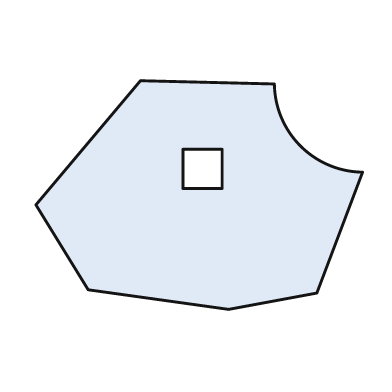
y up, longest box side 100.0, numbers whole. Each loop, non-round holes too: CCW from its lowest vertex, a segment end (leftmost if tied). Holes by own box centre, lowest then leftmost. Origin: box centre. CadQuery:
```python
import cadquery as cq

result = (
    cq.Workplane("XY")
    .moveTo(9.0, -35.0)
    .lineTo(36.0, -30.0)
    .lineTo(50.0, 7.0)
    .threePointArc((31.0, 15.0), (23.0, 34.0))
    .lineTo(-18.0, 35.0)
    .lineTo(-50.0, -3.0)
    .lineTo(-34.0, -29.0)
    .close()
    .moveTo(-5.0, 2.0)
    .lineTo(7.0, 2.0)
    .lineTo(7.0, 14.0)
    .lineTo(-5.0, 14.0)
    .close()
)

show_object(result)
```